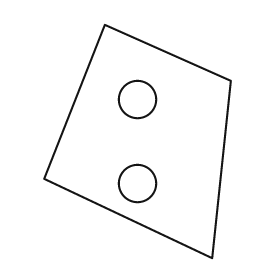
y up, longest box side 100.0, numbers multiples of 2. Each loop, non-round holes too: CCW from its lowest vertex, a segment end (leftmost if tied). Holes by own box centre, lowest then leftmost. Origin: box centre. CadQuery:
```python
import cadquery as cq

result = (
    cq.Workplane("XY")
    .moveTo(32.0, -50.0)
    .lineTo(40.0, 26.0)
    .lineTo(-14.0, 50.0)
    .lineTo(-40.0, -16.0)
    .close()
    .moveTo(0.0, -18.0)
    .circle(8.0)
    .moveTo(0.0, 18.0)
    .circle(8.0)
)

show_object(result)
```